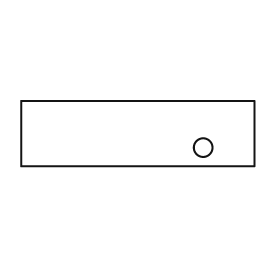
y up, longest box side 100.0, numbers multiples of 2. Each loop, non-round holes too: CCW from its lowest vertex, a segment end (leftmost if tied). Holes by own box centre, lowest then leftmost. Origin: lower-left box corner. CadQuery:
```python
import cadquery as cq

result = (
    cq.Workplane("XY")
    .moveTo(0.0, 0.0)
    .lineTo(100.0, 0.0)
    .lineTo(100.0, 28.0)
    .lineTo(0.0, 28.0)
    .close()
    .moveTo(78.0, 8.0)
    .circle(4.0)
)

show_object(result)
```